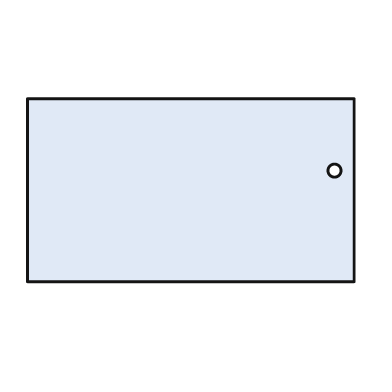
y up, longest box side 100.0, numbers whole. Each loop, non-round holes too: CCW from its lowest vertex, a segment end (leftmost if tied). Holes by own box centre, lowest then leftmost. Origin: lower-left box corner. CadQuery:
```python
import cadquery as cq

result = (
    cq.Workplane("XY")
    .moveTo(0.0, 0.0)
    .lineTo(100.0, 0.0)
    .lineTo(100.0, 56.0)
    .lineTo(0.0, 56.0)
    .close()
    .moveTo(94.0, 34.0)
    .circle(2.0)
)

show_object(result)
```